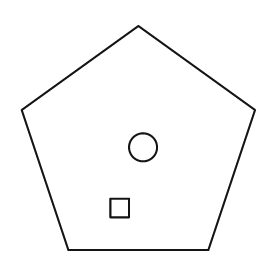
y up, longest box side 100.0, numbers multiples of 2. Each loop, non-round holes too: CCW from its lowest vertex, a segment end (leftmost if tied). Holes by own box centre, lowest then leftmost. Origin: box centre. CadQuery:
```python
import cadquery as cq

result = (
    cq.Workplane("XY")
    .moveTo(-30.0, -48.0)
    .lineTo(30.0, -48.0)
    .lineTo(50.0, 12.0)
    .lineTo(0.0, 48.0)
    .lineTo(-50.0, 12.0)
    .close()
    .moveTo(-12.0, -34.0)
    .lineTo(-4.0, -34.0)
    .lineTo(-4.0, -26.0)
    .lineTo(-12.0, -26.0)
    .close()
    .moveTo(2.0, -4.0)
    .circle(6.0)
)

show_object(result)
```